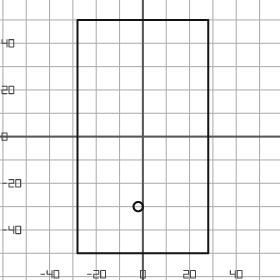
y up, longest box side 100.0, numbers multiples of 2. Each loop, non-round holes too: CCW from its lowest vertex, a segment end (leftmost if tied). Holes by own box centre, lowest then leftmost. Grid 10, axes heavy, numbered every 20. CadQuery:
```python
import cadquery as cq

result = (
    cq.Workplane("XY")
    .moveTo(-28.0, -50.0)
    .lineTo(28.0, -50.0)
    .lineTo(28.0, 50.0)
    .lineTo(-28.0, 50.0)
    .close()
    .moveTo(-2.0, -30.0)
    .circle(2.0)
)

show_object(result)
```